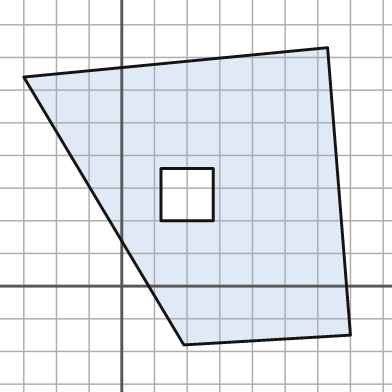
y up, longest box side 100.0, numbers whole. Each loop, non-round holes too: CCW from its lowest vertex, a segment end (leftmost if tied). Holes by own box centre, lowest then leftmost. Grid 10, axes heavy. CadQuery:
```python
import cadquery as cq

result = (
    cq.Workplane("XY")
    .moveTo(19.0, -18.0)
    .lineTo(70.0, -15.0)
    .lineTo(63.0, 73.0)
    .lineTo(-30.0, 64.0)
    .close()
    .moveTo(12.0, 20.0)
    .lineTo(28.0, 20.0)
    .lineTo(28.0, 36.0)
    .lineTo(12.0, 36.0)
    .close()
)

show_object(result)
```